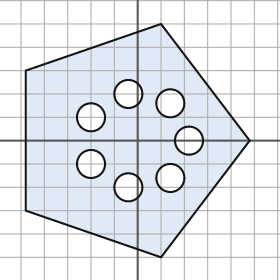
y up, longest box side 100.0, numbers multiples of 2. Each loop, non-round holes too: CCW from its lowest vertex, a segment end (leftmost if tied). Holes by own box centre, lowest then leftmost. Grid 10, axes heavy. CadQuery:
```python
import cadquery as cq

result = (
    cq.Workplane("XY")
    .moveTo(10.0, -50.0)
    .lineTo(48.0, 0.0)
    .lineTo(10.0, 50.0)
    .lineTo(-48.0, 30.0)
    .lineTo(-48.0, -30.0)
    .close()
    .moveTo(-4.0, -20.0)
    .circle(6.0)
    .moveTo(14.0, -16.0)
    .circle(6.0)
    .moveTo(-20.0, -10.0)
    .circle(6.0)
    .moveTo(22.0, 0.0)
    .circle(6.0)
    .moveTo(-20.0, 10.0)
    .circle(6.0)
    .moveTo(14.0, 16.0)
    .circle(6.0)
    .moveTo(-4.0, 20.0)
    .circle(6.0)
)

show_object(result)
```